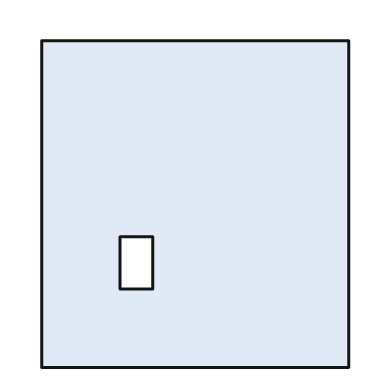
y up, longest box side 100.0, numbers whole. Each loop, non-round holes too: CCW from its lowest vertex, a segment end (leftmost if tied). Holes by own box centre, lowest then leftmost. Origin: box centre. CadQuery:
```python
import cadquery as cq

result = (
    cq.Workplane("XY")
    .moveTo(-47.0, -50.0)
    .lineTo(47.0, -50.0)
    .lineTo(47.0, 50.0)
    .lineTo(-47.0, 50.0)
    .close()
    .moveTo(-23.0, -26.0)
    .lineTo(-13.0, -26.0)
    .lineTo(-13.0, -10.0)
    .lineTo(-23.0, -10.0)
    .close()
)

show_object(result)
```